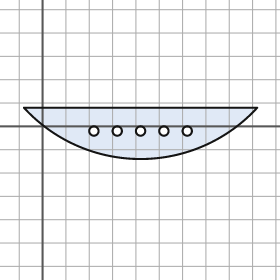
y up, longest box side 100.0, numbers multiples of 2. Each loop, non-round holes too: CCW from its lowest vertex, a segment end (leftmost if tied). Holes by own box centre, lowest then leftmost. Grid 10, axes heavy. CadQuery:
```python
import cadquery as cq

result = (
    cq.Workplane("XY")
    .moveTo(-8.0, 8.0)
    .threePointArc((42.0, -14.0), (92.0, 8.0))
    .close()
    .moveTo(22.0, -2.0)
    .circle(2.0)
    .moveTo(32.0, -2.0)
    .circle(2.0)
    .moveTo(42.0, -2.0)
    .circle(2.0)
    .moveTo(52.0, -2.0)
    .circle(2.0)
    .moveTo(62.0, -2.0)
    .circle(2.0)
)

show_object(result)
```